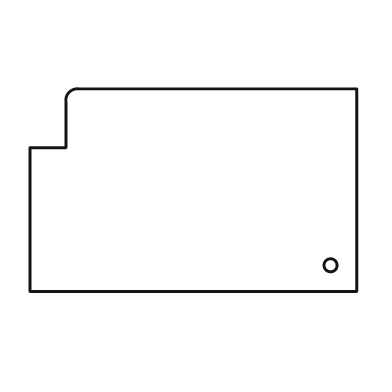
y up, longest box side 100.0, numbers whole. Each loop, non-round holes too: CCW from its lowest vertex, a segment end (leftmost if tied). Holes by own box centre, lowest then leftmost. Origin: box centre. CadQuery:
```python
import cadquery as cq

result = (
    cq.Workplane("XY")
    .moveTo(-50.0, -31.0)
    .lineTo(50.0, -31.0)
    .lineTo(50.0, 31.0)
    .lineTo(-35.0, 31.0)
    .threePointArc((-38.0, 30.0), (-39.0, 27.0))
    .lineTo(-39.0, 13.0)
    .lineTo(-50.0, 13.0)
    .close()
    .moveTo(42.0, -23.0)
    .circle(2.0)
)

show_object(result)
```